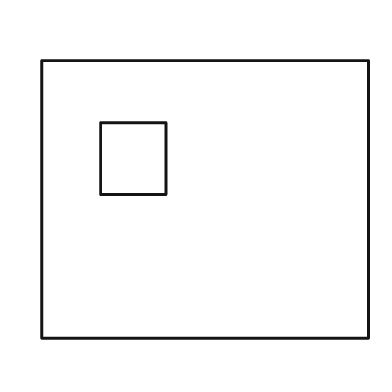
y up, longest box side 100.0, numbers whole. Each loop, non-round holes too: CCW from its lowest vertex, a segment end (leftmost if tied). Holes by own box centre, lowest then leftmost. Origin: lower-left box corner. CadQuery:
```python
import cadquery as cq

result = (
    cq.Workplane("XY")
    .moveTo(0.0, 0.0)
    .lineTo(100.0, 0.0)
    .lineTo(100.0, 85.0)
    .lineTo(0.0, 85.0)
    .close()
    .moveTo(18.0, 44.0)
    .lineTo(38.0, 44.0)
    .lineTo(38.0, 66.0)
    .lineTo(18.0, 66.0)
    .close()
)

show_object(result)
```